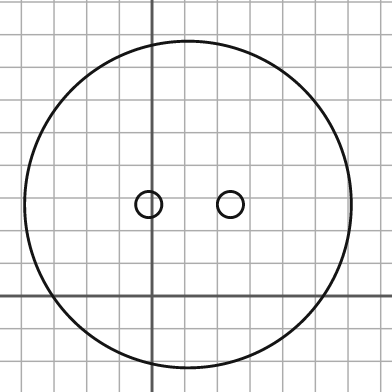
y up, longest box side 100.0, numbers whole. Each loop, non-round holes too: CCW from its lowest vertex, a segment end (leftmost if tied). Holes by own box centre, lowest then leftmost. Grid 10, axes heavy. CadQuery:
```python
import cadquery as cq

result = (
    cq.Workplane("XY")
    .moveTo(11.0, 28.0)
    .circle(50.0)
    .moveTo(-1.0, 28.0)
    .circle(4.0)
    .moveTo(24.0, 28.0)
    .circle(4.0)
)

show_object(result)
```